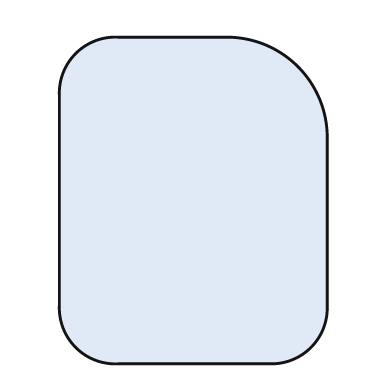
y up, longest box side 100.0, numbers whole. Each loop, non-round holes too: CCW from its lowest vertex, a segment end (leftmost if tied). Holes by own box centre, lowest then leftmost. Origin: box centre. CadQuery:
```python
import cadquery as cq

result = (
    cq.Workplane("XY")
    .moveTo(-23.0, -50.0)
    .lineTo(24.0, -50.0)
    .threePointArc((36.0, -45.0), (41.0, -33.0))
    .lineTo(41.0, 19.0)
    .threePointArc((32.0, 41.0), (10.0, 50.0))
    .lineTo(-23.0, 50.0)
    .threePointArc((-36.0, 45.0), (-41.0, 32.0))
    .lineTo(-41.0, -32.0)
    .threePointArc((-36.0, -45.0), (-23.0, -50.0))
    .close()
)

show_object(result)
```